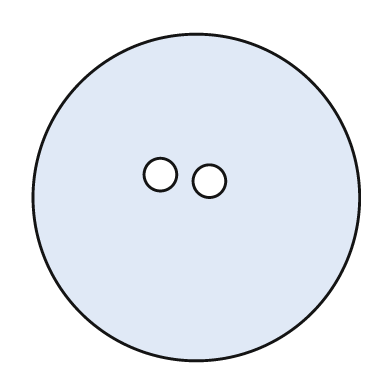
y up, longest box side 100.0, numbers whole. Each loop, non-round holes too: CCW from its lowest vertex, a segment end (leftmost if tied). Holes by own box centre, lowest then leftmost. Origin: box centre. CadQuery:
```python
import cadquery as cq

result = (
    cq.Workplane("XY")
    .moveTo(0.0, 0.0)
    .circle(50.0)
    .moveTo(4.0, 5.0)
    .circle(5.0)
    .moveTo(-11.0, 7.0)
    .circle(5.0)
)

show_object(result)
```